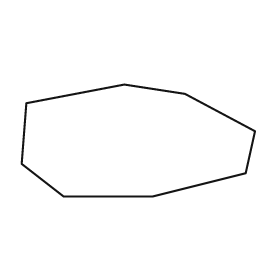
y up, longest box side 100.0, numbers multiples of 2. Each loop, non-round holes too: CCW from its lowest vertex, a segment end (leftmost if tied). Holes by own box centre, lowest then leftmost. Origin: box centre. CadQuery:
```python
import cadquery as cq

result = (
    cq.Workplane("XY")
    .moveTo(-32.0, -24.0)
    .lineTo(6.0, -24.0)
    .lineTo(46.0, -14.0)
    .lineTo(50.0, 4.0)
    .lineTo(20.0, 20.0)
    .lineTo(-6.0, 24.0)
    .lineTo(-48.0, 16.0)
    .lineTo(-50.0, -10.0)
    .close()
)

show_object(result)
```